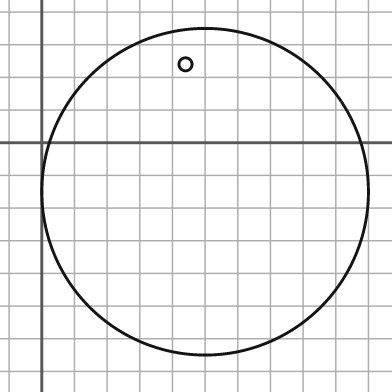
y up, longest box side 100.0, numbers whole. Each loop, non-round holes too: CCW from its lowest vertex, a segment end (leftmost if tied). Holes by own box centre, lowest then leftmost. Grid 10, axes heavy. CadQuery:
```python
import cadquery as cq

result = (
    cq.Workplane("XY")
    .moveTo(50.0, -15.0)
    .circle(50.0)
    .moveTo(44.0, 24.0)
    .circle(2.0)
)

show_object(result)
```